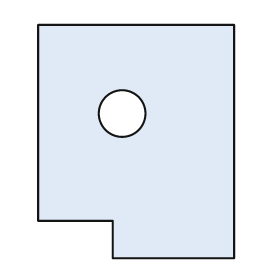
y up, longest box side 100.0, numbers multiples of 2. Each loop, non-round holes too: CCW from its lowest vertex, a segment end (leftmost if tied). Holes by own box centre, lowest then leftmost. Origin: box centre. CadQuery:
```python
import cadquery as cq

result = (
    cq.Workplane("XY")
    .moveTo(-10.0, -50.0)
    .lineTo(42.0, -50.0)
    .lineTo(42.0, 50.0)
    .lineTo(-42.0, 50.0)
    .lineTo(-42.0, -34.0)
    .lineTo(-10.0, -34.0)
    .close()
    .moveTo(-6.0, 12.0)
    .circle(10.0)
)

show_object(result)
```